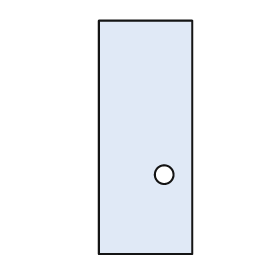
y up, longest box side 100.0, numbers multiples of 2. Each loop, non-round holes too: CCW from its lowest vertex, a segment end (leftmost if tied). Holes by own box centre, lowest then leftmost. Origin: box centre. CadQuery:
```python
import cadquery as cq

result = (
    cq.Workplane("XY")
    .moveTo(-20.0, -50.0)
    .lineTo(20.0, -50.0)
    .lineTo(20.0, 50.0)
    .lineTo(-20.0, 50.0)
    .close()
    .moveTo(8.0, -16.0)
    .circle(4.0)
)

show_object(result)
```